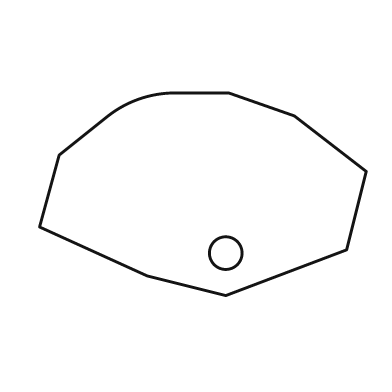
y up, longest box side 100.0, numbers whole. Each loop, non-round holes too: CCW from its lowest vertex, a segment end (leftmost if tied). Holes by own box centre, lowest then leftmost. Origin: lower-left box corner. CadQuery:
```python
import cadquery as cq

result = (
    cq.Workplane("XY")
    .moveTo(57.0, 0.0)
    .lineTo(94.0, 14.0)
    .lineTo(100.0, 38.0)
    .lineTo(78.0, 55.0)
    .lineTo(58.0, 62.0)
    .lineTo(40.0, 62.0)
    .threePointArc((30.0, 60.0), (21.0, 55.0))
    .lineTo(6.0, 43.0)
    .lineTo(0.0, 21.0)
    .lineTo(33.0, 6.0)
    .close()
    .moveTo(57.0, 13.0)
    .circle(5.0)
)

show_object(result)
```